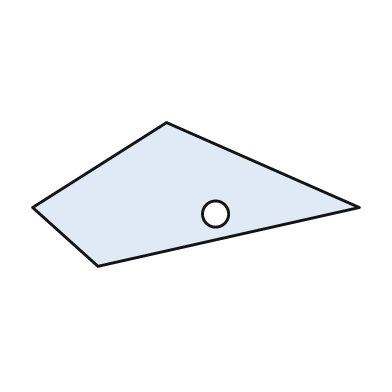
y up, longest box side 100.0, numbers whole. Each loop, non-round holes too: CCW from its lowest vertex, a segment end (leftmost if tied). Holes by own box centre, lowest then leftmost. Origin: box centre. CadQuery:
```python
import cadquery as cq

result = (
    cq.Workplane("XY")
    .moveTo(-30.0, -22.0)
    .lineTo(50.0, -4.0)
    .lineTo(-9.0, 22.0)
    .lineTo(-50.0, -4.0)
    .close()
    .moveTo(6.0, -6.0)
    .circle(4.0)
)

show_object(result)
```